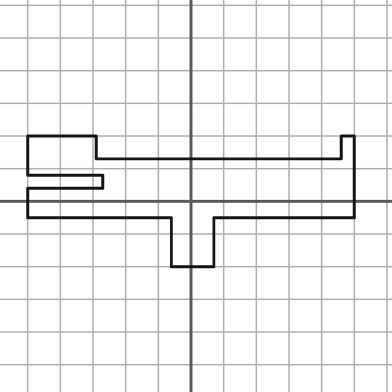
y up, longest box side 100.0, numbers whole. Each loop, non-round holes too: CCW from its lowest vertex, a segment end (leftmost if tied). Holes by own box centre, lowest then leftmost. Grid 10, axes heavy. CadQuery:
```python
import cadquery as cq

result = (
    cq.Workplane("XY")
    .moveTo(-6.0, -20.0)
    .lineTo(7.0, -20.0)
    .lineTo(7.0, -5.0)
    .lineTo(50.0, -5.0)
    .lineTo(50.0, 20.0)
    .lineTo(46.0, 20.0)
    .lineTo(46.0, 13.0)
    .lineTo(-29.0, 13.0)
    .lineTo(-29.0, 20.0)
    .lineTo(-50.0, 20.0)
    .lineTo(-50.0, 8.0)
    .lineTo(-27.0, 8.0)
    .lineTo(-27.0, 4.0)
    .lineTo(-50.0, 4.0)
    .lineTo(-50.0, -5.0)
    .lineTo(-6.0, -5.0)
    .close()
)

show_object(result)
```